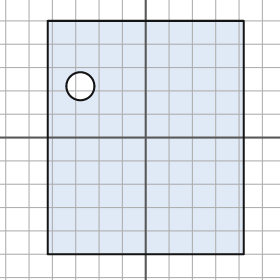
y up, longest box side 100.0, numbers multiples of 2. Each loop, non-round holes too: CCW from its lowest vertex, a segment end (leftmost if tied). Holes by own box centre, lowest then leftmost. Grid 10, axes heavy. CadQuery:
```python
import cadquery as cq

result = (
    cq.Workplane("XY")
    .moveTo(-42.0, -50.0)
    .lineTo(42.0, -50.0)
    .lineTo(42.0, 50.0)
    .lineTo(-42.0, 50.0)
    .close()
    .moveTo(-28.0, 22.0)
    .circle(6.0)
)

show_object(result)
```